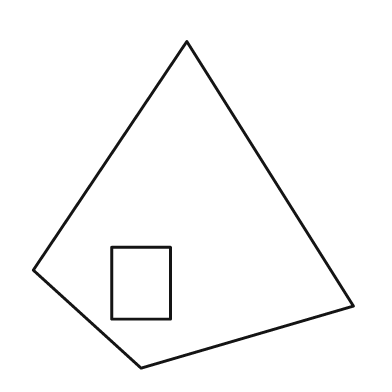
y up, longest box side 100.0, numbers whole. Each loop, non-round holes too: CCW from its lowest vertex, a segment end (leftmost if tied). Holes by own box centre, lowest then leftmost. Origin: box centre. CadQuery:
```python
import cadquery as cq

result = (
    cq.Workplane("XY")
    .moveTo(-16.0, -50.0)
    .lineTo(49.0, -31.0)
    .lineTo(-2.0, 50.0)
    .lineTo(-49.0, -20.0)
    .close()
    .moveTo(-25.0, -35.0)
    .lineTo(-7.0, -35.0)
    .lineTo(-7.0, -13.0)
    .lineTo(-25.0, -13.0)
    .close()
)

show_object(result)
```